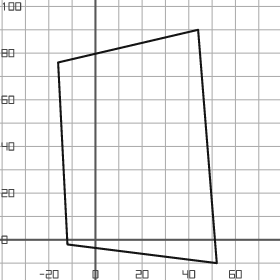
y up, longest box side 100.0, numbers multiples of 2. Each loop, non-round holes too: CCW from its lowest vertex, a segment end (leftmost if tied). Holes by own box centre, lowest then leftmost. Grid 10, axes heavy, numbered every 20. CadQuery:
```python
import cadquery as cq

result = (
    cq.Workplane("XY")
    .moveTo(52.0, -10.0)
    .lineTo(44.0, 90.0)
    .lineTo(-16.0, 76.0)
    .lineTo(-12.0, -2.0)
    .close()
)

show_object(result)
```